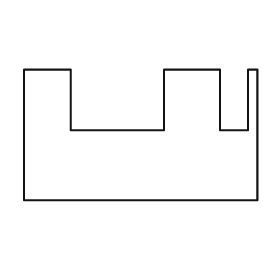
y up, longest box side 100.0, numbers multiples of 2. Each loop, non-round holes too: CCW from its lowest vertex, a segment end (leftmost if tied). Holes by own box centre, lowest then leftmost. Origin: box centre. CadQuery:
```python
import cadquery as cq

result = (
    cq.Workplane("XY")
    .moveTo(-50.0, -28.0)
    .lineTo(50.0, -28.0)
    .lineTo(50.0, 28.0)
    .lineTo(46.0, 28.0)
    .lineTo(46.0, 2.0)
    .lineTo(34.0, 2.0)
    .lineTo(34.0, 28.0)
    .lineTo(10.0, 28.0)
    .lineTo(10.0, 2.0)
    .lineTo(-30.0, 2.0)
    .lineTo(-30.0, 28.0)
    .lineTo(-50.0, 28.0)
    .close()
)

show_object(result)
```